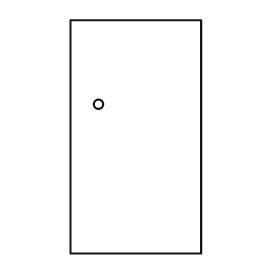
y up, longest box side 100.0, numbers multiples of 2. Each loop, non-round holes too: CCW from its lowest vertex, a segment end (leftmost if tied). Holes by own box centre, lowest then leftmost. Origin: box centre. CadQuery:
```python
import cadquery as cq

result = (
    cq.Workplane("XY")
    .moveTo(-28.0, -50.0)
    .lineTo(28.0, -50.0)
    .lineTo(28.0, 50.0)
    .lineTo(-28.0, 50.0)
    .close()
    .moveTo(-16.0, 14.0)
    .circle(2.0)
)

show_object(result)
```